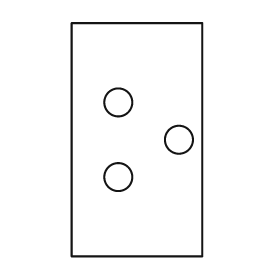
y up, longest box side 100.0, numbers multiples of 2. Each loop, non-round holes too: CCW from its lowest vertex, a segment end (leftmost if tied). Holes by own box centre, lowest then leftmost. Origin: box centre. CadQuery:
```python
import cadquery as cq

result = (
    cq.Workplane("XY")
    .moveTo(-28.0, -50.0)
    .lineTo(28.0, -50.0)
    .lineTo(28.0, 50.0)
    .lineTo(-28.0, 50.0)
    .close()
    .moveTo(-8.0, -16.0)
    .circle(6.0)
    .moveTo(18.0, 0.0)
    .circle(6.0)
    .moveTo(-8.0, 16.0)
    .circle(6.0)
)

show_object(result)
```